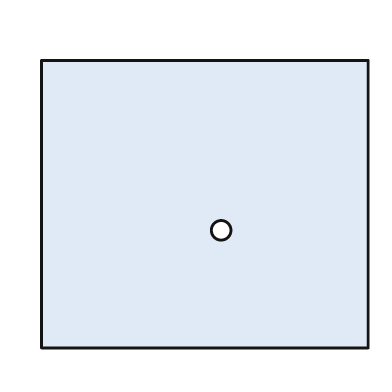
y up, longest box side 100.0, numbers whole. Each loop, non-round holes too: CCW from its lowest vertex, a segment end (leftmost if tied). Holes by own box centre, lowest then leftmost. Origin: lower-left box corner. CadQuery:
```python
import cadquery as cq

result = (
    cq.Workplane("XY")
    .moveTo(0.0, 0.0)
    .lineTo(100.0, 0.0)
    .lineTo(100.0, 88.0)
    .lineTo(0.0, 88.0)
    .close()
    .moveTo(55.0, 36.0)
    .circle(3.0)
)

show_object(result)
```